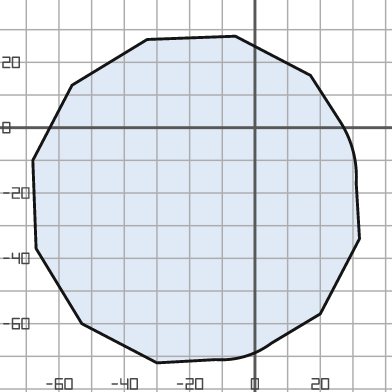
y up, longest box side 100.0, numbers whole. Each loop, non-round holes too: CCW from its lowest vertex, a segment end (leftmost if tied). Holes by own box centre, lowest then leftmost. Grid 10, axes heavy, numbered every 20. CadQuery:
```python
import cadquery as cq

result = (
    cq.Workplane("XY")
    .moveTo(-30.0, -72.0)
    .lineTo(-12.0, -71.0)
    .threePointArc((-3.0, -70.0), (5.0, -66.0))
    .lineTo(20.0, -57.0)
    .lineTo(32.0, -34.0)
    .lineTo(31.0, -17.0)
    .threePointArc((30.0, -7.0), (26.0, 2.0))
    .lineTo(17.0, 16.0)
    .lineTo(-6.0, 28.0)
    .lineTo(-33.0, 27.0)
    .lineTo(-56.0, 13.0)
    .lineTo(-68.0, -10.0)
    .lineTo(-67.0, -37.0)
    .lineTo(-53.0, -60.0)
    .close()
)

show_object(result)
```